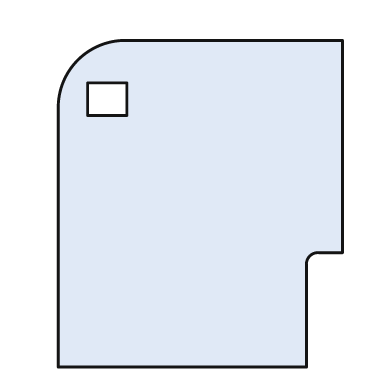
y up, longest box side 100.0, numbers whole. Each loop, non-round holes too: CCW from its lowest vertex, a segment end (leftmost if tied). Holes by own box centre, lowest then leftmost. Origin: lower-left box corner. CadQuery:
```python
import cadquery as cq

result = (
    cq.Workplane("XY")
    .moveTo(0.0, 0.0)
    .lineTo(76.0, 0.0)
    .lineTo(76.0, 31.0)
    .threePointArc((77.0, 34.0), (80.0, 35.0))
    .lineTo(87.0, 35.0)
    .lineTo(87.0, 100.0)
    .lineTo(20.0, 100.0)
    .threePointArc((6.0, 94.0), (0.0, 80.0))
    .close()
    .moveTo(9.0, 77.0)
    .lineTo(21.0, 77.0)
    .lineTo(21.0, 87.0)
    .lineTo(9.0, 87.0)
    .close()
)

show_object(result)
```